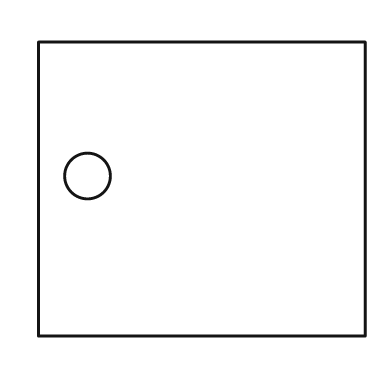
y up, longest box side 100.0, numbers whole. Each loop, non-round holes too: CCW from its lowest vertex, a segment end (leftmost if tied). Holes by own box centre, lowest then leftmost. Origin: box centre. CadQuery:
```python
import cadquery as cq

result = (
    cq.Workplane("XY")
    .moveTo(-50.0, -45.0)
    .lineTo(50.0, -45.0)
    .lineTo(50.0, 45.0)
    .lineTo(-50.0, 45.0)
    .close()
    .moveTo(-35.0, 4.0)
    .circle(7.0)
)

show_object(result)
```